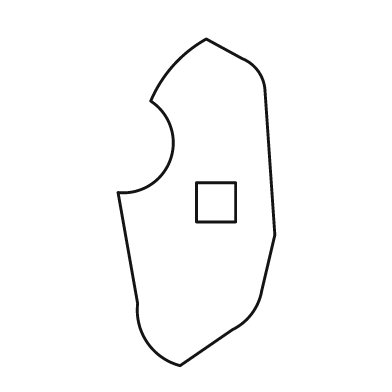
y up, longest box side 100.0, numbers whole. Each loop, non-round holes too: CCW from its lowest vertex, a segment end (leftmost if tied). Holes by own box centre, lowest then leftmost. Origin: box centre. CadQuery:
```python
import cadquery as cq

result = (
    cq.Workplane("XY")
    .moveTo(-5.0, -50.0)
    .lineTo(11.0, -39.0)
    .threePointArc((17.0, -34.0), (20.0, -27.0))
    .lineTo(24.0, -10.0)
    .lineTo(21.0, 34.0)
    .threePointArc((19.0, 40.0), (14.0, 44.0))
    .lineTo(3.0, 50.0)
    .threePointArc((-7.0, 42.0), (-14.0, 31.0))
    .threePointArc((-8.0, 13.0), (-24.0, 3.0))
    .lineTo(-18.0, -31.0)
    .threePointArc((-15.0, -43.0), (-5.0, -50.0))
    .close()
    .moveTo(0.0, -6.0)
    .lineTo(12.0, -6.0)
    .lineTo(12.0, 6.0)
    .lineTo(0.0, 6.0)
    .close()
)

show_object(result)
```